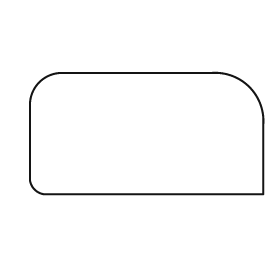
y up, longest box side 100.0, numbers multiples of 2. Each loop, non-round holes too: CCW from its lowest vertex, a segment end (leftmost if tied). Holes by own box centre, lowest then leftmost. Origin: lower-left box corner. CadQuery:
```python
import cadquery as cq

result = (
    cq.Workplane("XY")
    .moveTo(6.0, 0.0)
    .lineTo(100.0, 0.0)
    .lineTo(100.0, 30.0)
    .threePointArc((94.0, 46.0), (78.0, 52.0))
    .lineTo(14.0, 52.0)
    .threePointArc((4.0, 48.0), (0.0, 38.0))
    .lineTo(0.0, 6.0)
    .threePointArc((2.0, 2.0), (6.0, 0.0))
    .close()
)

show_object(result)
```